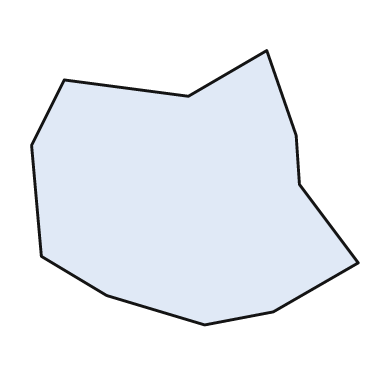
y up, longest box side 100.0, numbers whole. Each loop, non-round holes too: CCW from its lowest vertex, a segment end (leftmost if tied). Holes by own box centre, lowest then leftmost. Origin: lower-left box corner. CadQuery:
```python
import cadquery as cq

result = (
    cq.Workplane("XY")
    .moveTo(53.0, 0.0)
    .lineTo(74.0, 4.0)
    .lineTo(100.0, 19.0)
    .lineTo(82.0, 43.0)
    .lineTo(81.0, 58.0)
    .lineTo(72.0, 84.0)
    .lineTo(48.0, 70.0)
    .lineTo(10.0, 75.0)
    .lineTo(0.0, 55.0)
    .lineTo(3.0, 21.0)
    .lineTo(23.0, 9.0)
    .close()
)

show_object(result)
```